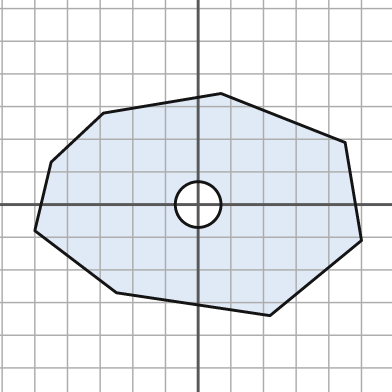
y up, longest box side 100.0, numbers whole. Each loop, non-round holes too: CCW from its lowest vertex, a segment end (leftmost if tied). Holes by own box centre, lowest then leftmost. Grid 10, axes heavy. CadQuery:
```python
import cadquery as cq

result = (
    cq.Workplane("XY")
    .moveTo(22.0, -34.0)
    .lineTo(50.0, -11.0)
    .lineTo(45.0, 19.0)
    .lineTo(7.0, 34.0)
    .lineTo(-29.0, 28.0)
    .lineTo(-45.0, 13.0)
    .lineTo(-50.0, -8.0)
    .lineTo(-25.0, -27.0)
    .close()
    .moveTo(0.0, 0.0)
    .circle(7.0)
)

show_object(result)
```